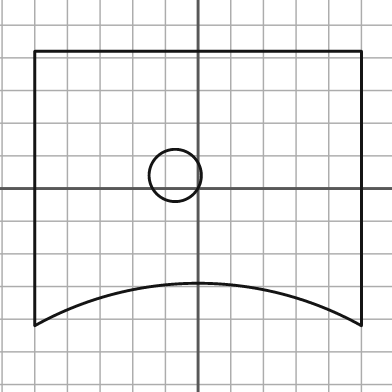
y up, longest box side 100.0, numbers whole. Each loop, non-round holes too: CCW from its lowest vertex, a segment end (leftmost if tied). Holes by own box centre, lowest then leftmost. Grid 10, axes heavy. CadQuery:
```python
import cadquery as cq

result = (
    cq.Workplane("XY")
    .moveTo(-50.0, -42.0)
    .threePointArc((0.0, -29.0), (50.0, -42.0))
    .lineTo(50.0, 42.0)
    .lineTo(-50.0, 42.0)
    .close()
    .moveTo(-7.0, 4.0)
    .circle(8.0)
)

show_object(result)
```